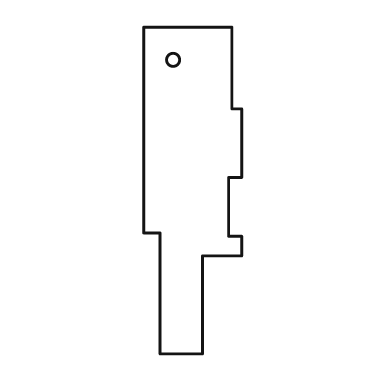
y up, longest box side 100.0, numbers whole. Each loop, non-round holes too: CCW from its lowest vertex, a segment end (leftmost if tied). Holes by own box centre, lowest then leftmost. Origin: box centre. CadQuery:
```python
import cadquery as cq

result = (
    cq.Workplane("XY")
    .moveTo(-10.0, -50.0)
    .lineTo(3.0, -50.0)
    .lineTo(3.0, -20.0)
    .lineTo(15.0, -20.0)
    .lineTo(15.0, -14.0)
    .lineTo(11.0, -14.0)
    .lineTo(11.0, 4.0)
    .lineTo(15.0, 4.0)
    .lineTo(15.0, 25.0)
    .lineTo(12.0, 25.0)
    .lineTo(12.0, 50.0)
    .lineTo(-15.0, 50.0)
    .lineTo(-15.0, -13.0)
    .lineTo(-10.0, -13.0)
    .close()
    .moveTo(-6.0, 40.0)
    .circle(2.0)
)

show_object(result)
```